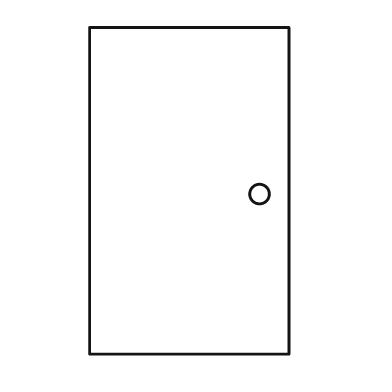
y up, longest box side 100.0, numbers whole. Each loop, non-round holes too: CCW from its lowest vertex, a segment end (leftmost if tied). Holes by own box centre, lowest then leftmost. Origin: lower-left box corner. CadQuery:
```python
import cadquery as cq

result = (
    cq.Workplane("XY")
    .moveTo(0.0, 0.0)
    .lineTo(61.0, 0.0)
    .lineTo(61.0, 100.0)
    .lineTo(0.0, 100.0)
    .close()
    .moveTo(52.0, 49.0)
    .circle(3.0)
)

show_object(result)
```